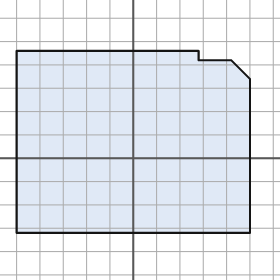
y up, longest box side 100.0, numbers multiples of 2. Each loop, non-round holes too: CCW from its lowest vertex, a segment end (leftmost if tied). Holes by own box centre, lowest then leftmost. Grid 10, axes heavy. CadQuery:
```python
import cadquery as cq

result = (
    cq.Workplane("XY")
    .moveTo(-50.0, -32.0)
    .lineTo(50.0, -32.0)
    .lineTo(50.0, 34.0)
    .lineTo(42.0, 42.0)
    .lineTo(28.0, 42.0)
    .lineTo(28.0, 46.0)
    .lineTo(-50.0, 46.0)
    .close()
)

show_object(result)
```